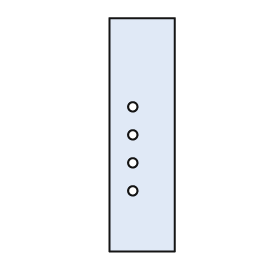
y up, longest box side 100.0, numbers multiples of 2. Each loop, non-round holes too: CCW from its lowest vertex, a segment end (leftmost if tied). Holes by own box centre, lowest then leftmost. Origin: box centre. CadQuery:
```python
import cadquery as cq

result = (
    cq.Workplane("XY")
    .moveTo(-14.0, -50.0)
    .lineTo(14.0, -50.0)
    .lineTo(14.0, 50.0)
    .lineTo(-14.0, 50.0)
    .close()
    .moveTo(-4.0, -24.0)
    .circle(2.0)
    .moveTo(-4.0, -12.0)
    .circle(2.0)
    .moveTo(-4.0, 0.0)
    .circle(2.0)
    .moveTo(-4.0, 12.0)
    .circle(2.0)
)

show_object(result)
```